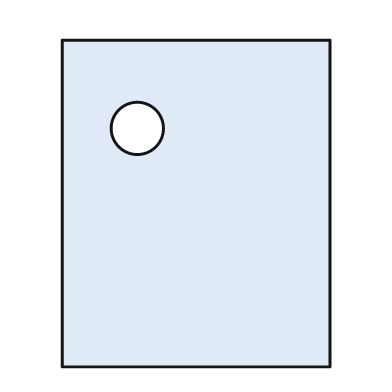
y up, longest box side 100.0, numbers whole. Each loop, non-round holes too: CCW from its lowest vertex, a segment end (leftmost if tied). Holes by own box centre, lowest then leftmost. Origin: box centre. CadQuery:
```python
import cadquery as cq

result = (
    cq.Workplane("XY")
    .moveTo(-41.0, -50.0)
    .lineTo(41.0, -50.0)
    .lineTo(41.0, 50.0)
    .lineTo(-41.0, 50.0)
    .close()
    .moveTo(-18.0, 23.0)
    .circle(8.0)
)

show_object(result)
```